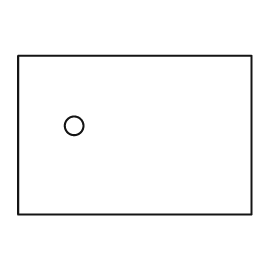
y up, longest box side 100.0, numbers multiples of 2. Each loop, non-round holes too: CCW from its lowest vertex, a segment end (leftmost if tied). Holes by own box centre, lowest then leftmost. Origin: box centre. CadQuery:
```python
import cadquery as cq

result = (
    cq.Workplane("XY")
    .moveTo(-50.0, -34.0)
    .lineTo(50.0, -34.0)
    .lineTo(50.0, 34.0)
    .lineTo(-50.0, 34.0)
    .close()
    .moveTo(-26.0, 4.0)
    .circle(4.0)
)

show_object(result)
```